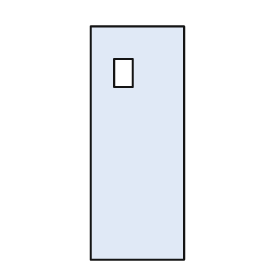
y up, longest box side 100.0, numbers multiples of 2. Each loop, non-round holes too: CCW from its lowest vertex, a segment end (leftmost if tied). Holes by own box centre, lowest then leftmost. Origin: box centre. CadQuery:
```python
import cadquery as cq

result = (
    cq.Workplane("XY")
    .moveTo(-20.0, -50.0)
    .lineTo(20.0, -50.0)
    .lineTo(20.0, 50.0)
    .lineTo(-20.0, 50.0)
    .close()
    .moveTo(-10.0, 24.0)
    .lineTo(-2.0, 24.0)
    .lineTo(-2.0, 36.0)
    .lineTo(-10.0, 36.0)
    .close()
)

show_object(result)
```